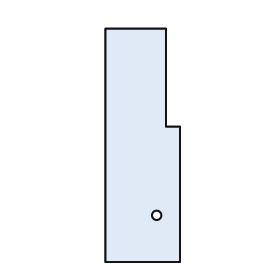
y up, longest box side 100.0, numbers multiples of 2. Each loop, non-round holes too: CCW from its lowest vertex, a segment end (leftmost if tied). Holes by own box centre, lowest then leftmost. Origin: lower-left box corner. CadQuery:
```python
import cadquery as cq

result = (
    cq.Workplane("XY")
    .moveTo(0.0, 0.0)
    .lineTo(32.0, 0.0)
    .lineTo(32.0, 58.0)
    .lineTo(26.0, 58.0)
    .lineTo(26.0, 100.0)
    .lineTo(0.0, 100.0)
    .close()
    .moveTo(22.0, 20.0)
    .circle(2.0)
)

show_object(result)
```